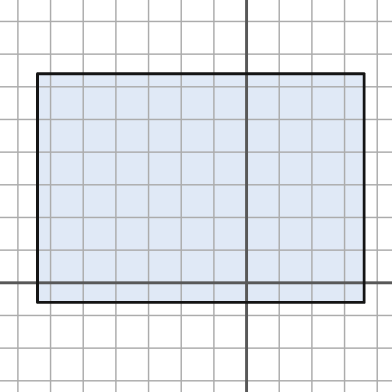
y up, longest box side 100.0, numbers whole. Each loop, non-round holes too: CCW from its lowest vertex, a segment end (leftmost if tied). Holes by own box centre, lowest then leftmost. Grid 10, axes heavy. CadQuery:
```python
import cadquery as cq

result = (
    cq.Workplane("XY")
    .moveTo(-64.0, -6.0)
    .lineTo(36.0, -6.0)
    .lineTo(36.0, 64.0)
    .lineTo(-64.0, 64.0)
    .close()
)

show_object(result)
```